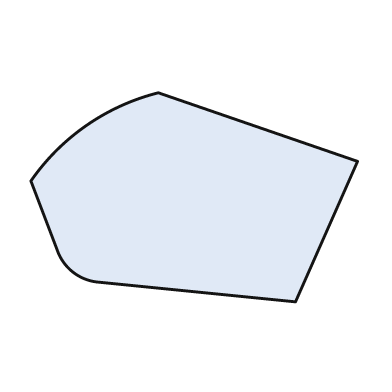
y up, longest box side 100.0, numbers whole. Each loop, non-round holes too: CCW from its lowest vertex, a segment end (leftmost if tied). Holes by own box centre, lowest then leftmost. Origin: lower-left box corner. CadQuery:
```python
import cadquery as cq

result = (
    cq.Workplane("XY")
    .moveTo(81.0, 0.0)
    .lineTo(100.0, 43.0)
    .lineTo(39.0, 64.0)
    .threePointArc((17.0, 54.0), (0.0, 37.0))
    .lineTo(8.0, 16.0)
    .threePointArc((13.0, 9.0), (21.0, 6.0))
    .close()
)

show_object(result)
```